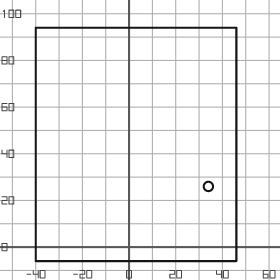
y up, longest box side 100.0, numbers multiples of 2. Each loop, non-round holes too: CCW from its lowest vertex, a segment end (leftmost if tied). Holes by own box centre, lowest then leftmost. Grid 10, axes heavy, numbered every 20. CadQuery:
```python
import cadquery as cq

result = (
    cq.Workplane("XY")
    .moveTo(-40.0, -6.0)
    .lineTo(46.0, -6.0)
    .lineTo(46.0, 94.0)
    .lineTo(-40.0, 94.0)
    .close()
    .moveTo(34.0, 26.0)
    .circle(2.0)
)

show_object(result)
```